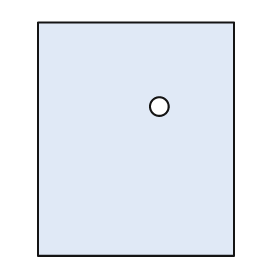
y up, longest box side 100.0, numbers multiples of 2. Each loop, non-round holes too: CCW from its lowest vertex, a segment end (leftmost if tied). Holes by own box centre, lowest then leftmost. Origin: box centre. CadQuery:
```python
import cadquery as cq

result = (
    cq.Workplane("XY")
    .moveTo(-42.0, -50.0)
    .lineTo(42.0, -50.0)
    .lineTo(42.0, 50.0)
    .lineTo(-42.0, 50.0)
    .close()
    .moveTo(10.0, 14.0)
    .circle(4.0)
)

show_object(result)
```